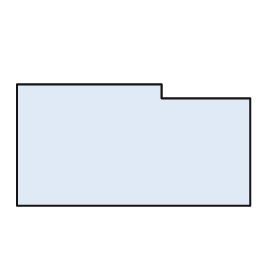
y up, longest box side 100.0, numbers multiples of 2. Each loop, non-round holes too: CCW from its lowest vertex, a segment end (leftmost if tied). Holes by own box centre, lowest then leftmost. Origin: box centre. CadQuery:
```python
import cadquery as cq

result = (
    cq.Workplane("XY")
    .moveTo(-50.0, -26.0)
    .lineTo(50.0, -26.0)
    .lineTo(50.0, 20.0)
    .lineTo(12.0, 20.0)
    .lineTo(12.0, 26.0)
    .lineTo(-50.0, 26.0)
    .close()
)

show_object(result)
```